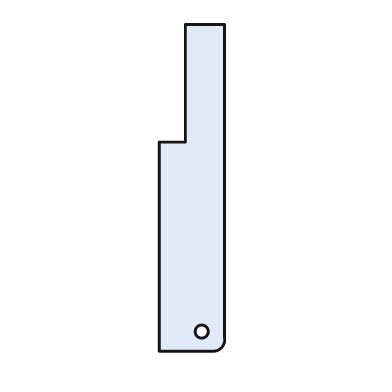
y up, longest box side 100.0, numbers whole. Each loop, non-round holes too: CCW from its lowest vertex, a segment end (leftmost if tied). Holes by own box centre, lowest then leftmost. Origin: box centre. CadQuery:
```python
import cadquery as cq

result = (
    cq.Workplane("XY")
    .moveTo(-10.0, -50.0)
    .lineTo(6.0, -50.0)
    .threePointArc((9.0, -49.0), (10.0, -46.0))
    .lineTo(10.0, 50.0)
    .lineTo(-2.0, 50.0)
    .lineTo(-2.0, 14.0)
    .lineTo(-10.0, 14.0)
    .close()
    .moveTo(3.0, -44.0)
    .circle(2.0)
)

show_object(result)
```